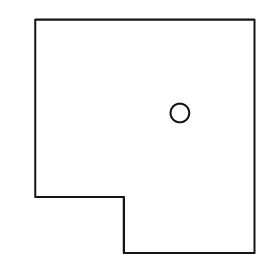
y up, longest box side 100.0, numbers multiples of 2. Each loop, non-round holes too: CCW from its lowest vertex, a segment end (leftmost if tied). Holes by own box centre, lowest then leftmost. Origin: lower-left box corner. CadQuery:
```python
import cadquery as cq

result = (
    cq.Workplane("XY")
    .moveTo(38.0, 0.0)
    .lineTo(94.0, 0.0)
    .lineTo(94.0, 100.0)
    .lineTo(0.0, 100.0)
    .lineTo(0.0, 24.0)
    .lineTo(38.0, 24.0)
    .close()
    .moveTo(62.0, 60.0)
    .circle(4.0)
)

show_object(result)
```